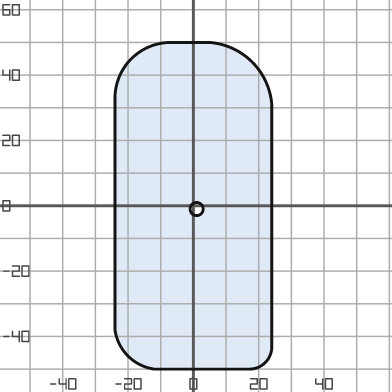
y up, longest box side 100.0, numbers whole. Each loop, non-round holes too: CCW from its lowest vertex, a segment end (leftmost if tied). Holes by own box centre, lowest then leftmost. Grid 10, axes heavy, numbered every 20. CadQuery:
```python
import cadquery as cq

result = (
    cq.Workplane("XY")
    .moveTo(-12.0, -50.0)
    .lineTo(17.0, -50.0)
    .threePointArc((22.0, -48.0), (24.0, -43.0))
    .lineTo(24.0, 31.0)
    .threePointArc((18.0, 44.0), (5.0, 50.0))
    .lineTo(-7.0, 50.0)
    .threePointArc((-19.0, 45.0), (-24.0, 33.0))
    .lineTo(-24.0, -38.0)
    .threePointArc((-20.0, -46.0), (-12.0, -50.0))
    .close()
    .moveTo(1.0, -1.0)
    .circle(2.0)
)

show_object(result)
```